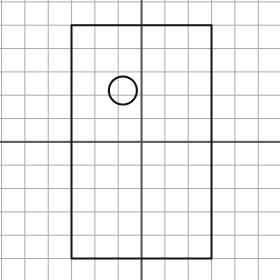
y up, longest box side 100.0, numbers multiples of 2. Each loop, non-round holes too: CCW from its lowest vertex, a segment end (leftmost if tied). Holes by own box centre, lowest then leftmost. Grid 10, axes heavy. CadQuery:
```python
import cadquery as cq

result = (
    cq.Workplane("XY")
    .moveTo(-30.0, -50.0)
    .lineTo(30.0, -50.0)
    .lineTo(30.0, 50.0)
    .lineTo(-30.0, 50.0)
    .close()
    .moveTo(-8.0, 22.0)
    .circle(6.0)
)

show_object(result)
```